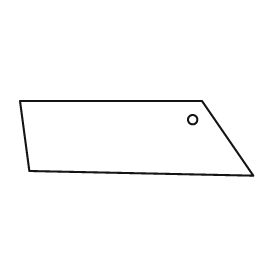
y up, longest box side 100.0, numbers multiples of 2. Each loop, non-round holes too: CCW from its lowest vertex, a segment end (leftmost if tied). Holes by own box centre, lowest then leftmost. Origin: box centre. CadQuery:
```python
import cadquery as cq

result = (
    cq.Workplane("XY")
    .moveTo(50.0, -16.0)
    .lineTo(28.0, 16.0)
    .lineTo(-50.0, 16.0)
    .lineTo(-46.0, -14.0)
    .close()
    .moveTo(24.0, 8.0)
    .circle(2.0)
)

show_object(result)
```